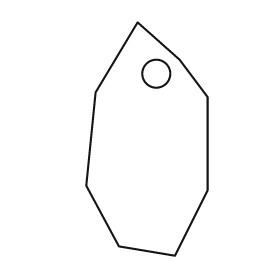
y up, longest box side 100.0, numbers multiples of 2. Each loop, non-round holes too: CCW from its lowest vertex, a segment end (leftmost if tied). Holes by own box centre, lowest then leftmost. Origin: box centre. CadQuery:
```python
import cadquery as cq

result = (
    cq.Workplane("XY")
    .moveTo(12.0, -50.0)
    .lineTo(26.0, -22.0)
    .lineTo(26.0, 18.0)
    .lineTo(14.0, 34.0)
    .lineTo(-4.0, 50.0)
    .lineTo(-22.0, 20.0)
    .lineTo(-26.0, -20.0)
    .lineTo(-12.0, -46.0)
    .close()
    .moveTo(4.0, 28.0)
    .circle(6.0)
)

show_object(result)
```